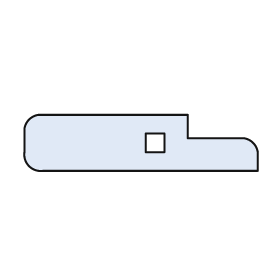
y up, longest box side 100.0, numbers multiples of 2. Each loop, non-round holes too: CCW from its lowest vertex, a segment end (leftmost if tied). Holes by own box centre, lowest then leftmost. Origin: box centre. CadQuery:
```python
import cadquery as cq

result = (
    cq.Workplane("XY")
    .moveTo(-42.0, -12.0)
    .lineTo(50.0, -12.0)
    .lineTo(50.0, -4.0)
    .threePointArc((48.0, 0.0), (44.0, 2.0))
    .lineTo(20.0, 2.0)
    .lineTo(20.0, 12.0)
    .lineTo(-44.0, 12.0)
    .threePointArc((-48.0, 10.0), (-50.0, 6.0))
    .lineTo(-50.0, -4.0)
    .threePointArc((-48.0, -10.0), (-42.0, -12.0))
    .close()
    .moveTo(2.0, -4.0)
    .lineTo(10.0, -4.0)
    .lineTo(10.0, 4.0)
    .lineTo(2.0, 4.0)
    .close()
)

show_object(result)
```